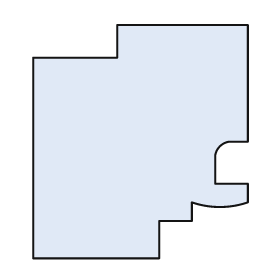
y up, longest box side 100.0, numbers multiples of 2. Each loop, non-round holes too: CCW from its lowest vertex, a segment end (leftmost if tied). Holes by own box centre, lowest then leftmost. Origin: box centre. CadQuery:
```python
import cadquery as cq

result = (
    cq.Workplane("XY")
    .moveTo(-46.0, -50.0)
    .lineTo(8.0, -50.0)
    .lineTo(8.0, -34.0)
    .lineTo(22.0, -34.0)
    .lineTo(22.0, -26.0)
    .threePointArc((34.0, -28.0), (46.0, -26.0))
    .lineTo(46.0, -18.0)
    .lineTo(32.0, -18.0)
    .lineTo(32.0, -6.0)
    .threePointArc((34.0, -2.0), (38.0, 0.0))
    .lineTo(46.0, 0.0)
    .lineTo(46.0, 50.0)
    .lineTo(-10.0, 50.0)
    .lineTo(-10.0, 36.0)
    .lineTo(-46.0, 36.0)
    .close()
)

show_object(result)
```